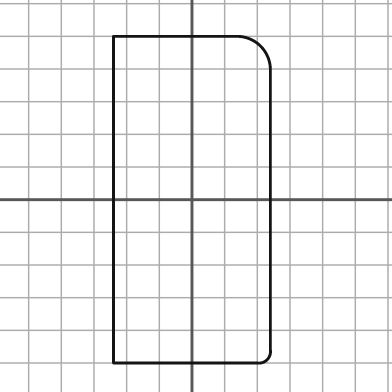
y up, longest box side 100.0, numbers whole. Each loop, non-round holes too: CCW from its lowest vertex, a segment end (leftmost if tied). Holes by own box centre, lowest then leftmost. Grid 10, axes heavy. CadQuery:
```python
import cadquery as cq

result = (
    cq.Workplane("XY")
    .moveTo(-24.0, -50.0)
    .lineTo(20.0, -50.0)
    .threePointArc((23.0, -49.0), (24.0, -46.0))
    .lineTo(24.0, 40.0)
    .threePointArc((21.0, 47.0), (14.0, 50.0))
    .lineTo(-24.0, 50.0)
    .close()
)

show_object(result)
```